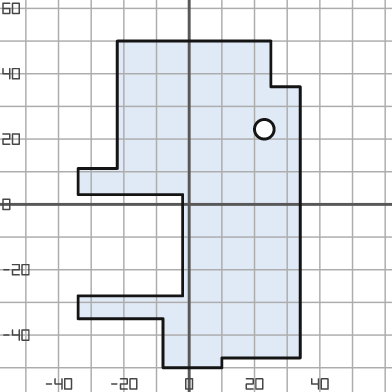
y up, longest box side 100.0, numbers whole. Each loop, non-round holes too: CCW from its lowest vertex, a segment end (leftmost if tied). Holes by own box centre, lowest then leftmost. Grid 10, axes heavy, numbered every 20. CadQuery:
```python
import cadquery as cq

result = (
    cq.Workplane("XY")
    .moveTo(-8.0, -50.0)
    .lineTo(10.0, -50.0)
    .lineTo(10.0, -47.0)
    .lineTo(34.0, -47.0)
    .lineTo(34.0, 36.0)
    .lineTo(25.0, 36.0)
    .lineTo(25.0, 50.0)
    .lineTo(-22.0, 50.0)
    .lineTo(-22.0, 11.0)
    .lineTo(-34.0, 11.0)
    .lineTo(-34.0, 3.0)
    .lineTo(-2.0, 3.0)
    .lineTo(-2.0, -28.0)
    .lineTo(-34.0, -28.0)
    .lineTo(-34.0, -35.0)
    .lineTo(-8.0, -35.0)
    .close()
    .moveTo(23.0, 23.0)
    .circle(3.0)
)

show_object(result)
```